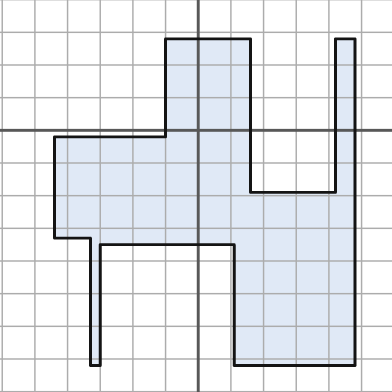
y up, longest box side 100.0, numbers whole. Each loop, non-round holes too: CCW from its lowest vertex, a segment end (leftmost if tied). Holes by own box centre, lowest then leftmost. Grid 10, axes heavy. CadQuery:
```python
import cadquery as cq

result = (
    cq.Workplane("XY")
    .moveTo(-33.0, -72.0)
    .lineTo(-30.0, -72.0)
    .lineTo(-30.0, -35.0)
    .lineTo(11.0, -35.0)
    .lineTo(11.0, -72.0)
    .lineTo(48.0, -72.0)
    .lineTo(48.0, 28.0)
    .lineTo(42.0, 28.0)
    .lineTo(42.0, -19.0)
    .lineTo(16.0, -19.0)
    .lineTo(16.0, 28.0)
    .lineTo(-10.0, 28.0)
    .lineTo(-10.0, -2.0)
    .lineTo(-44.0, -2.0)
    .lineTo(-44.0, -33.0)
    .lineTo(-33.0, -33.0)
    .close()
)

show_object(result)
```